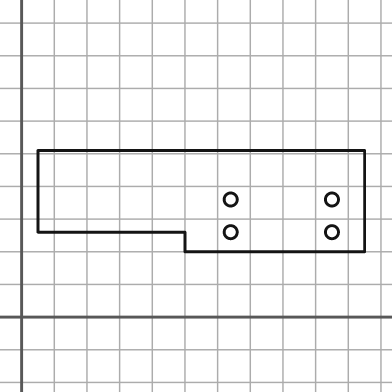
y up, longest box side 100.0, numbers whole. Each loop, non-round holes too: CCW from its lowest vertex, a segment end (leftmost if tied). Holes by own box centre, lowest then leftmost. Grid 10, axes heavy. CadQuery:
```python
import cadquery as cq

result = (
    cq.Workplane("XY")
    .moveTo(50.0, 20.0)
    .lineTo(105.0, 20.0)
    .lineTo(105.0, 51.0)
    .lineTo(5.0, 51.0)
    .lineTo(5.0, 26.0)
    .lineTo(50.0, 26.0)
    .close()
    .moveTo(64.0, 26.0)
    .circle(2.0)
    .moveTo(95.0, 26.0)
    .circle(2.0)
    .moveTo(64.0, 36.0)
    .circle(2.0)
    .moveTo(95.0, 36.0)
    .circle(2.0)
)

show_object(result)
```